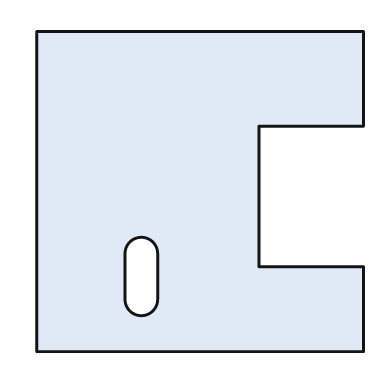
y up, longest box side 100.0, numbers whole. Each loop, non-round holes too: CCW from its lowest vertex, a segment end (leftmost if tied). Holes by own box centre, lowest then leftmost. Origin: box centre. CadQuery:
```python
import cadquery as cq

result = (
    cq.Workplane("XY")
    .moveTo(-50.0, -49.0)
    .lineTo(50.0, -49.0)
    .lineTo(50.0, -23.0)
    .lineTo(18.0, -23.0)
    .lineTo(18.0, 20.0)
    .lineTo(50.0, 20.0)
    .lineTo(50.0, 49.0)
    .lineTo(-50.0, 49.0)
    .close()
    .moveTo(-23.0, -33.0)
    .threePointArc((-18.0, -38.0), (-13.0, -33.0))
    .lineTo(-13.0, -19.0)
    .threePointArc((-18.0, -14.0), (-23.0, -19.0))
    .close()
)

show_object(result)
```